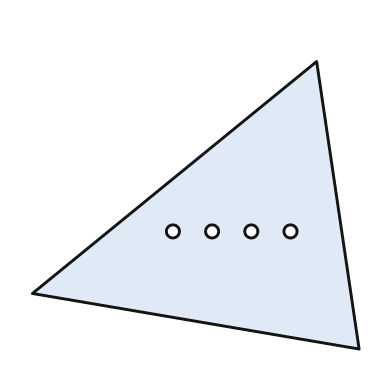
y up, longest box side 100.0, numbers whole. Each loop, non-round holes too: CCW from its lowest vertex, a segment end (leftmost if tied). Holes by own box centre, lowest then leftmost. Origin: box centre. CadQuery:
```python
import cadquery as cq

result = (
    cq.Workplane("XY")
    .moveTo(50.0, -44.0)
    .lineTo(37.0, 44.0)
    .lineTo(-50.0, -27.0)
    .close()
    .moveTo(-7.0, -8.0)
    .circle(2.0)
    .moveTo(5.0, -8.0)
    .circle(2.0)
    .moveTo(17.0, -8.0)
    .circle(2.0)
    .moveTo(29.0, -8.0)
    .circle(2.0)
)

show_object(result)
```